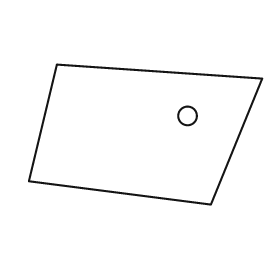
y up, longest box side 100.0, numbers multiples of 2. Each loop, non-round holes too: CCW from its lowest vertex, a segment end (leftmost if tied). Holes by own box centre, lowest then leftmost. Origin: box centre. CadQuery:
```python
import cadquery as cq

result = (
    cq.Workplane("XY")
    .moveTo(28.0, -30.0)
    .lineTo(50.0, 24.0)
    .lineTo(-38.0, 30.0)
    .lineTo(-50.0, -20.0)
    .close()
    .moveTo(18.0, 8.0)
    .circle(4.0)
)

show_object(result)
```